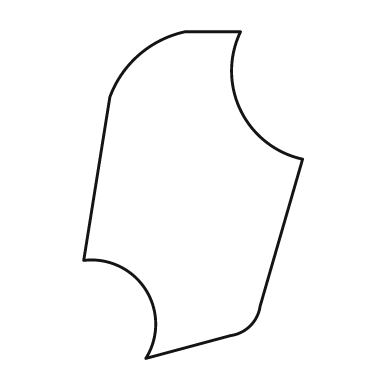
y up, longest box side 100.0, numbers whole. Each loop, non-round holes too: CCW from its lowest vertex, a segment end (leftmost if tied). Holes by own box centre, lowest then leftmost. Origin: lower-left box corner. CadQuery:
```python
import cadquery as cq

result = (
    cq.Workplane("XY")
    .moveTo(19.0, 0.0)
    .lineTo(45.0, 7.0)
    .threePointArc((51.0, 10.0), (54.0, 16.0))
    .lineTo(67.0, 61.0)
    .threePointArc((48.0, 76.0), (48.0, 100.0))
    .lineTo(31.0, 100.0)
    .threePointArc((17.0, 93.0), (8.0, 80.0))
    .lineTo(0.0, 30.0)
    .threePointArc((19.0, 21.0), (19.0, 0.0))
    .close()
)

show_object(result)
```